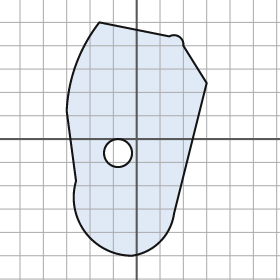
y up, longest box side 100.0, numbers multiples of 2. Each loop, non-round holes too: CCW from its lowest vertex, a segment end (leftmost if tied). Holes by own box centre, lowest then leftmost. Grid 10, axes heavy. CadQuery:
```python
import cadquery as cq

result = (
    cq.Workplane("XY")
    .moveTo(-2.0, -50.0)
    .threePointArc((10.0, -44.0), (16.0, -32.0))
    .lineTo(30.0, 24.0)
    .lineTo(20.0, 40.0)
    .threePointArc((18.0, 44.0), (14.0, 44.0))
    .lineTo(-16.0, 50.0)
    .threePointArc((-26.0, 32.0), (-30.0, 12.0))
    .lineTo(-26.0, -18.0)
    .threePointArc((-22.0, -40.0), (-2.0, -50.0))
    .close()
    .moveTo(-8.0, -6.0)
    .circle(6.0)
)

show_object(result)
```